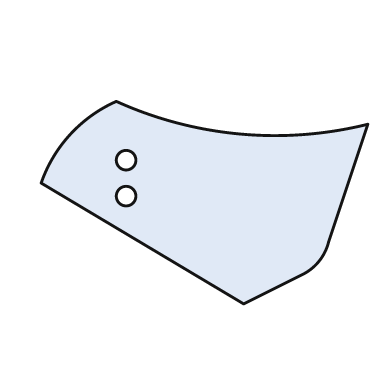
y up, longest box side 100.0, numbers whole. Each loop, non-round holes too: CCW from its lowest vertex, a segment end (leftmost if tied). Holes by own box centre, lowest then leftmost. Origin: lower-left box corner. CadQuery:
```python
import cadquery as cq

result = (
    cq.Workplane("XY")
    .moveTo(62.0, 0.0)
    .lineTo(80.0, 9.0)
    .threePointArc((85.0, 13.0), (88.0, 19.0))
    .lineTo(100.0, 55.0)
    .threePointArc((61.0, 52.0), (23.0, 62.0))
    .threePointArc((9.0, 52.0), (0.0, 37.0))
    .close()
    .moveTo(26.0, 33.0)
    .circle(3.0)
    .moveTo(26.0, 44.0)
    .circle(3.0)
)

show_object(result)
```